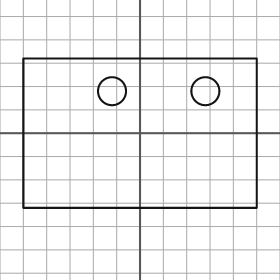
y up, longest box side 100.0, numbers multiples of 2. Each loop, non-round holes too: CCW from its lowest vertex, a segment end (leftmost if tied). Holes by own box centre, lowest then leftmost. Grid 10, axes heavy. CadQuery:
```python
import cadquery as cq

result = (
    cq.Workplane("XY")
    .moveTo(-50.0, -32.0)
    .lineTo(50.0, -32.0)
    .lineTo(50.0, 32.0)
    .lineTo(-50.0, 32.0)
    .close()
    .moveTo(-12.0, 18.0)
    .circle(6.0)
    .moveTo(28.0, 18.0)
    .circle(6.0)
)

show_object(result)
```